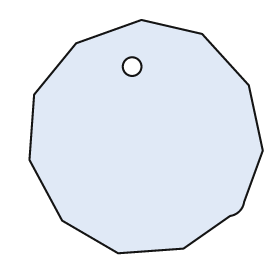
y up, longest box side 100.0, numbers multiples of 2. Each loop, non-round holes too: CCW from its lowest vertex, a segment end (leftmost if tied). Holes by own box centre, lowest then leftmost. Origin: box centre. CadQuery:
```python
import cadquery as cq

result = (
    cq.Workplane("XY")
    .moveTo(-12.0, -50.0)
    .lineTo(16.0, -48.0)
    .lineTo(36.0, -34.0)
    .threePointArc((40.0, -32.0), (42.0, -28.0))
    .lineTo(50.0, -6.0)
    .lineTo(44.0, 22.0)
    .lineTo(24.0, 44.0)
    .lineTo(-2.0, 50.0)
    .lineTo(-30.0, 40.0)
    .lineTo(-48.0, 18.0)
    .lineTo(-50.0, -10.0)
    .lineTo(-36.0, -36.0)
    .close()
    .moveTo(-6.0, 30.0)
    .circle(4.0)
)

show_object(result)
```